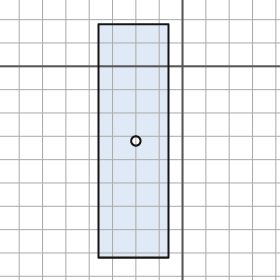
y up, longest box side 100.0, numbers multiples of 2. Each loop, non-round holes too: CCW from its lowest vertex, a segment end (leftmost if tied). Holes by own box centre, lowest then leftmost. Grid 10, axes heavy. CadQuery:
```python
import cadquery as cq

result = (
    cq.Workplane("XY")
    .moveTo(-36.0, -82.0)
    .lineTo(-6.0, -82.0)
    .lineTo(-6.0, 18.0)
    .lineTo(-36.0, 18.0)
    .close()
    .moveTo(-20.0, -32.0)
    .circle(2.0)
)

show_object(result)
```